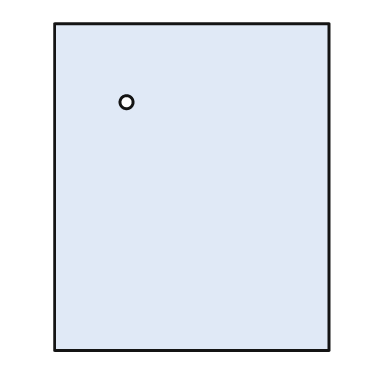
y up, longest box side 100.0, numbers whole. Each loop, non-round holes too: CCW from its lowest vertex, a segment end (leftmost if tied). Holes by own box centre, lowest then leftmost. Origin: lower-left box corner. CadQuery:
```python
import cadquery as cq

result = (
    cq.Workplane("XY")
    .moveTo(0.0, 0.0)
    .lineTo(84.0, 0.0)
    .lineTo(84.0, 100.0)
    .lineTo(0.0, 100.0)
    .close()
    .moveTo(22.0, 76.0)
    .circle(2.0)
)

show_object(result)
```